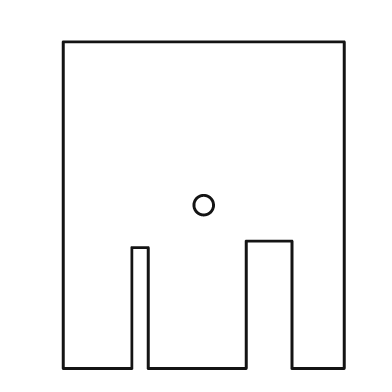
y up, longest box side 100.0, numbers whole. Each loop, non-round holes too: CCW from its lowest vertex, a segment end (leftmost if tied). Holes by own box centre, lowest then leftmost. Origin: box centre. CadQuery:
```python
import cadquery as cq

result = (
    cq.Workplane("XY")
    .moveTo(-43.0, -50.0)
    .lineTo(-22.0, -50.0)
    .lineTo(-22.0, -13.0)
    .lineTo(-17.0, -13.0)
    .lineTo(-17.0, -50.0)
    .lineTo(13.0, -50.0)
    .lineTo(13.0, -11.0)
    .lineTo(27.0, -11.0)
    .lineTo(27.0, -50.0)
    .lineTo(43.0, -50.0)
    .lineTo(43.0, 50.0)
    .lineTo(-43.0, 50.0)
    .close()
    .moveTo(0.0, 0.0)
    .circle(3.0)
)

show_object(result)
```